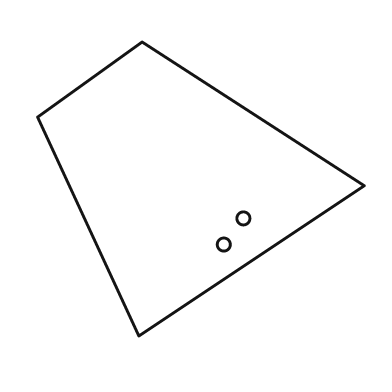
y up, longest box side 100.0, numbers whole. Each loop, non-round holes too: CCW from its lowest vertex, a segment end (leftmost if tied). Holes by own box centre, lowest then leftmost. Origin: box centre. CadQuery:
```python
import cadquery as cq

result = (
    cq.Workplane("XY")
    .moveTo(-19.0, -45.0)
    .lineTo(50.0, 1.0)
    .lineTo(-18.0, 45.0)
    .lineTo(-50.0, 22.0)
    .close()
    .moveTo(7.0, -17.0)
    .circle(2.0)
    .moveTo(13.0, -9.0)
    .circle(2.0)
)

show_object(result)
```